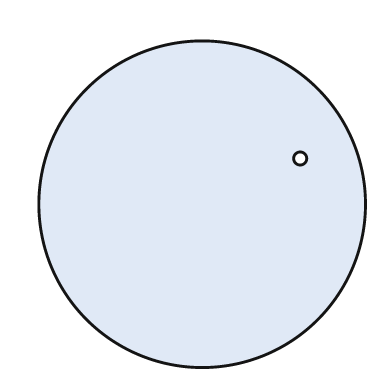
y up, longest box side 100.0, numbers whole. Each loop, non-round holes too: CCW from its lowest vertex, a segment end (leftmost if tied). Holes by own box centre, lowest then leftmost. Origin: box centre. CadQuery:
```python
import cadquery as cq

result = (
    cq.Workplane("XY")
    .moveTo(0.0, 0.0)
    .circle(50.0)
    .moveTo(30.0, 14.0)
    .circle(2.0)
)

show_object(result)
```